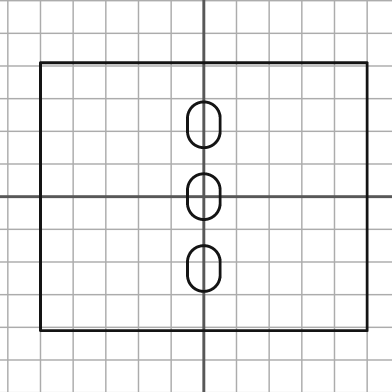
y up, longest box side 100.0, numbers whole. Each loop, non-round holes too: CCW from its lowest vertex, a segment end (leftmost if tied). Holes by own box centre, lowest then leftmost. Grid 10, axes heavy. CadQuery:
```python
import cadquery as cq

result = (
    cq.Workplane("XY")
    .moveTo(-50.0, -41.0)
    .lineTo(50.0, -41.0)
    .lineTo(50.0, 41.0)
    .lineTo(-50.0, 41.0)
    .close()
    .moveTo(-5.0, -24.0)
    .threePointArc((0.0, -29.0), (5.0, -24.0))
    .lineTo(5.0, -20.0)
    .threePointArc((0.0, -15.0), (-5.0, -20.0))
    .close()
    .moveTo(-5.0, -2.0)
    .threePointArc((0.0, -7.0), (5.0, -2.0))
    .lineTo(5.0, 2.0)
    .threePointArc((0.0, 7.0), (-5.0, 2.0))
    .close()
    .moveTo(-5.0, 20.0)
    .threePointArc((0.0, 15.0), (5.0, 20.0))
    .lineTo(5.0, 24.0)
    .threePointArc((0.0, 29.0), (-5.0, 24.0))
    .close()
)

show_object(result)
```